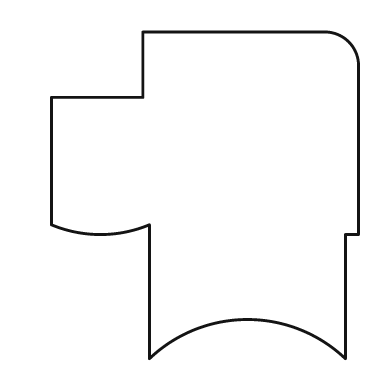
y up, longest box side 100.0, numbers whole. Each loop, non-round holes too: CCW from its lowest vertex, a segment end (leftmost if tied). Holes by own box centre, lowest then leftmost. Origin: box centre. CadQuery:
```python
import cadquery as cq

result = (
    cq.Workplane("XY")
    .moveTo(-17.0, -50.0)
    .threePointArc((13.0, -38.0), (43.0, -50.0))
    .lineTo(43.0, -12.0)
    .lineTo(47.0, -12.0)
    .lineTo(47.0, 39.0)
    .threePointArc((44.0, 47.0), (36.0, 50.0))
    .lineTo(-19.0, 50.0)
    .lineTo(-19.0, 30.0)
    .lineTo(-47.0, 30.0)
    .lineTo(-47.0, -9.0)
    .threePointArc((-32.0, -12.0), (-17.0, -9.0))
    .close()
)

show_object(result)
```